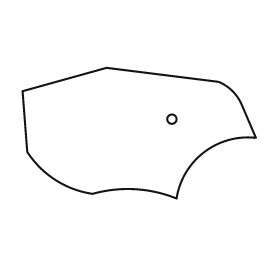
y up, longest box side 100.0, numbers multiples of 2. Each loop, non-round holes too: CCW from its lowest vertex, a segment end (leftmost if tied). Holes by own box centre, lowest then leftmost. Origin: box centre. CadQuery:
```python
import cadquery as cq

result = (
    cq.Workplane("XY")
    .moveTo(16.0, -28.0)
    .threePointArc((28.0, -8.0), (50.0, -2.0))
    .lineTo(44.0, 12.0)
    .threePointArc((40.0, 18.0), (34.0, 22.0))
    .lineTo(-14.0, 28.0)
    .lineTo(-50.0, 18.0)
    .lineTo(-48.0, -8.0)
    .threePointArc((-36.0, -20.0), (-20.0, -26.0))
    .threePointArc((-2.0, -24.0), (16.0, -28.0))
    .close()
    .moveTo(14.0, 6.0)
    .circle(2.0)
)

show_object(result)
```